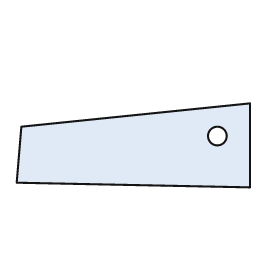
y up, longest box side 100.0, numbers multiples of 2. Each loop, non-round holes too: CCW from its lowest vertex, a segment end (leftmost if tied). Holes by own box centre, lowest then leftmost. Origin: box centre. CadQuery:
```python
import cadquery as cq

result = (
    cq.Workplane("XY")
    .moveTo(50.0, -18.0)
    .lineTo(50.0, 18.0)
    .lineTo(-48.0, 8.0)
    .lineTo(-50.0, -16.0)
    .close()
    .moveTo(36.0, 4.0)
    .circle(4.0)
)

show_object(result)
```